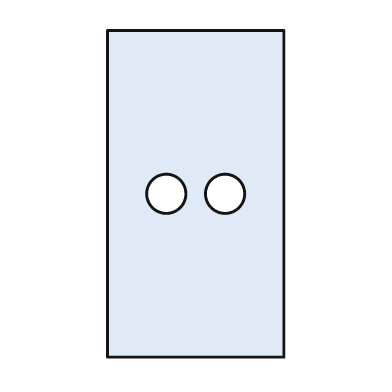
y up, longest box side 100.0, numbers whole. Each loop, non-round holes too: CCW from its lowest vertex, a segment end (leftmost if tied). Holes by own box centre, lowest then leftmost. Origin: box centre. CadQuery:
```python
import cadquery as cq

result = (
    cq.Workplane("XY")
    .moveTo(-27.0, -50.0)
    .lineTo(27.0, -50.0)
    .lineTo(27.0, 50.0)
    .lineTo(-27.0, 50.0)
    .close()
    .moveTo(-9.0, 0.0)
    .circle(6.0)
    .moveTo(9.0, 0.0)
    .circle(6.0)
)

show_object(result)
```